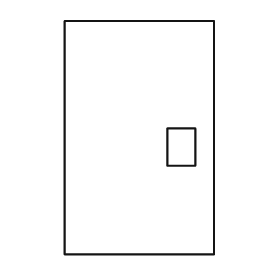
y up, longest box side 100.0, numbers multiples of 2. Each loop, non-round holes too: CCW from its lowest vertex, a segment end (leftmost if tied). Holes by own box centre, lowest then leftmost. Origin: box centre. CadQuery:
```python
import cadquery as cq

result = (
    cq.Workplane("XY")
    .moveTo(-32.0, -50.0)
    .lineTo(32.0, -50.0)
    .lineTo(32.0, 50.0)
    .lineTo(-32.0, 50.0)
    .close()
    .moveTo(12.0, -12.0)
    .lineTo(24.0, -12.0)
    .lineTo(24.0, 4.0)
    .lineTo(12.0, 4.0)
    .close()
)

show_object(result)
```